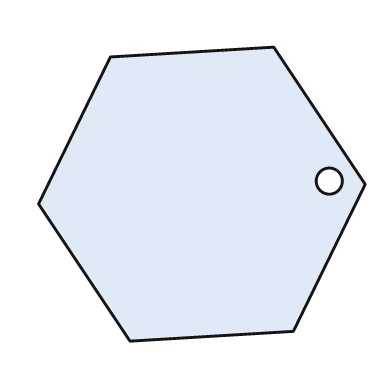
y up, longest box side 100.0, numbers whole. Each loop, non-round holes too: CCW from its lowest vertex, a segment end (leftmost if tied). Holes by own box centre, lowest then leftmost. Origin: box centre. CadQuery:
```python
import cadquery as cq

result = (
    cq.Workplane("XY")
    .moveTo(-22.0, -45.0)
    .lineTo(28.0, -42.0)
    .lineTo(50.0, 3.0)
    .lineTo(22.0, 45.0)
    .lineTo(-28.0, 42.0)
    .lineTo(-50.0, -3.0)
    .close()
    .moveTo(39.0, 4.0)
    .circle(4.0)
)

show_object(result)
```